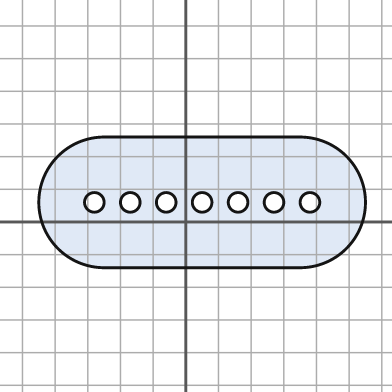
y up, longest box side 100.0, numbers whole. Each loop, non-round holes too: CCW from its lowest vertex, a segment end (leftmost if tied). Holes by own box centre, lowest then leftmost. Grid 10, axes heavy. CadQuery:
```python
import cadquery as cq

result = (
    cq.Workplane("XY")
    .moveTo(-25.0, -14.0)
    .lineTo(35.0, -14.0)
    .threePointArc((55.0, 6.0), (35.0, 26.0))
    .lineTo(-25.0, 26.0)
    .threePointArc((-45.0, 6.0), (-25.0, -14.0))
    .close()
    .moveTo(-28.0, 6.0)
    .circle(3.0)
    .moveTo(-17.0, 6.0)
    .circle(3.0)
    .moveTo(-6.0, 6.0)
    .circle(3.0)
    .moveTo(5.0, 6.0)
    .circle(3.0)
    .moveTo(16.0, 6.0)
    .circle(3.0)
    .moveTo(27.0, 6.0)
    .circle(3.0)
    .moveTo(38.0, 6.0)
    .circle(3.0)
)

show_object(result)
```